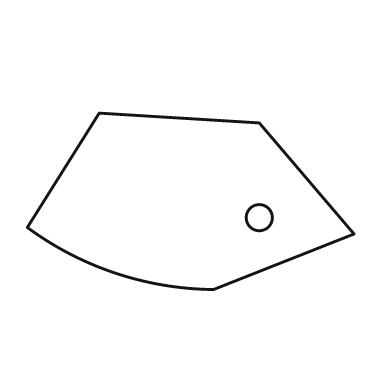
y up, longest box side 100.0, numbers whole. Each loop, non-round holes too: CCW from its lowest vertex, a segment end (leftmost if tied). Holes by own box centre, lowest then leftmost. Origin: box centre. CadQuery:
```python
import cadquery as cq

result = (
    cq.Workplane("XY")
    .moveTo(7.0, -27.0)
    .lineTo(50.0, -10.0)
    .lineTo(21.0, 24.0)
    .lineTo(-28.0, 27.0)
    .lineTo(-50.0, -8.0)
    .threePointArc((-23.0, -22.0), (7.0, -27.0))
    .close()
    .moveTo(21.0, -5.0)
    .circle(4.0)
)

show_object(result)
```